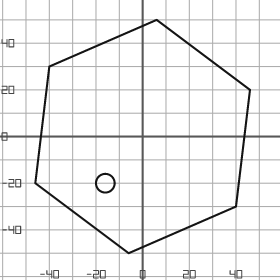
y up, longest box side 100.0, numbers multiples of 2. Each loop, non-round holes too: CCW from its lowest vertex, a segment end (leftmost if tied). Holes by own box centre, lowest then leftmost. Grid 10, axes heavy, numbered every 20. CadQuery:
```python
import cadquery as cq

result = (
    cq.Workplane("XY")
    .moveTo(-6.0, -50.0)
    .lineTo(40.0, -30.0)
    .lineTo(46.0, 20.0)
    .lineTo(6.0, 50.0)
    .lineTo(-40.0, 30.0)
    .lineTo(-46.0, -20.0)
    .close()
    .moveTo(-16.0, -20.0)
    .circle(4.0)
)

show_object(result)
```